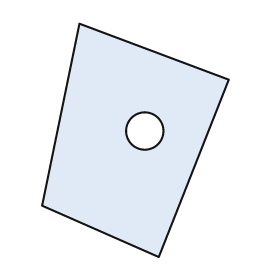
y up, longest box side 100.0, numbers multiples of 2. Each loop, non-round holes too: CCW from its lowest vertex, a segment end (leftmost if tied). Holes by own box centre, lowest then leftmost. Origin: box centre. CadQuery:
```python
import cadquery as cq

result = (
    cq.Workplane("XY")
    .moveTo(10.0, -50.0)
    .lineTo(40.0, 26.0)
    .lineTo(-24.0, 50.0)
    .lineTo(-40.0, -28.0)
    .close()
    .moveTo(4.0, 4.0)
    .circle(8.0)
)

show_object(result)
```